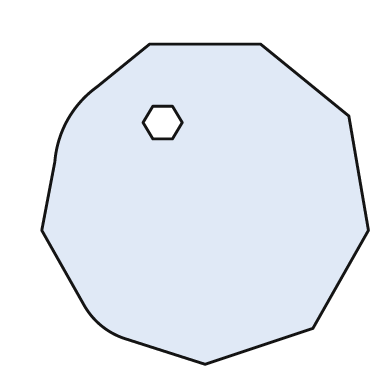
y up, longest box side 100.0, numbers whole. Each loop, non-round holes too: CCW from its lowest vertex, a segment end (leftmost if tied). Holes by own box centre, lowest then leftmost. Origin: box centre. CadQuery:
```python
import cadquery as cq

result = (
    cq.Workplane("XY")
    .moveTo(0.0, -49.0)
    .lineTo(33.0, -38.0)
    .lineTo(50.0, -8.0)
    .lineTo(44.0, 27.0)
    .lineTo(17.0, 49.0)
    .lineTo(-17.0, 49.0)
    .lineTo(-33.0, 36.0)
    .threePointArc((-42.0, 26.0), (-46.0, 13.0))
    .lineTo(-50.0, -8.0)
    .lineTo(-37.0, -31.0)
    .threePointArc((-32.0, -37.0), (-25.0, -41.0))
    .close()
    .moveTo(-16.0, 20.0)
    .lineTo(-10.0, 20.0)
    .lineTo(-7.0, 25.0)
    .lineTo(-10.0, 30.0)
    .lineTo(-16.0, 30.0)
    .lineTo(-19.0, 25.0)
    .close()
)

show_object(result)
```